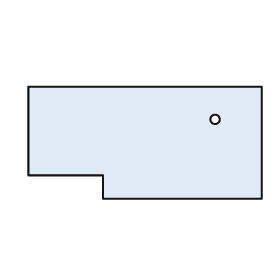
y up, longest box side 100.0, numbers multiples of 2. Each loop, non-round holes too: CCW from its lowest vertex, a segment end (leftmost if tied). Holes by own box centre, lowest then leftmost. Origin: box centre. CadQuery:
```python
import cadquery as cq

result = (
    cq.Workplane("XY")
    .moveTo(-18.0, -24.0)
    .lineTo(50.0, -24.0)
    .lineTo(50.0, 24.0)
    .lineTo(-50.0, 24.0)
    .lineTo(-50.0, -14.0)
    .lineTo(-18.0, -14.0)
    .close()
    .moveTo(30.0, 10.0)
    .circle(2.0)
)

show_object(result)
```